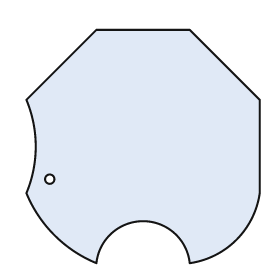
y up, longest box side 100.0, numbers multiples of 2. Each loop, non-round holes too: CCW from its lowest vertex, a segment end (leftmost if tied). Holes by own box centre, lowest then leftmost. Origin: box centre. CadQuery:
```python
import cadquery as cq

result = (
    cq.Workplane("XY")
    .moveTo(-20.0, -50.0)
    .threePointArc((0.0, -32.0), (20.0, -50.0))
    .threePointArc((40.0, -40.0), (50.0, -20.0))
    .lineTo(50.0, 20.0)
    .lineTo(20.0, 50.0)
    .lineTo(-20.0, 50.0)
    .lineTo(-50.0, 20.0)
    .threePointArc((-46.0, 0.0), (-50.0, -20.0))
    .threePointArc((-38.0, -38.0), (-20.0, -50.0))
    .close()
    .moveTo(-40.0, -14.0)
    .circle(2.0)
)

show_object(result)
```